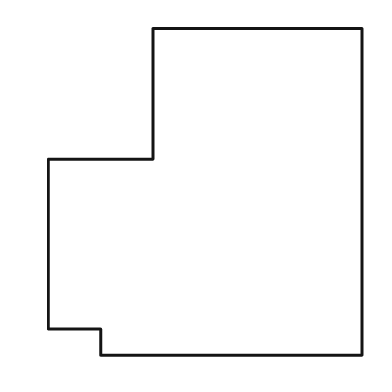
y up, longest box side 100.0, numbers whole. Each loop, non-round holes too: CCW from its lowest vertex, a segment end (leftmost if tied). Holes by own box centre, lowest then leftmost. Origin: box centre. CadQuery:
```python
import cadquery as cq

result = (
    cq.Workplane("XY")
    .moveTo(-32.0, -50.0)
    .lineTo(48.0, -50.0)
    .lineTo(48.0, 50.0)
    .lineTo(-16.0, 50.0)
    .lineTo(-16.0, 10.0)
    .lineTo(-48.0, 10.0)
    .lineTo(-48.0, -42.0)
    .lineTo(-32.0, -42.0)
    .close()
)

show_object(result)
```